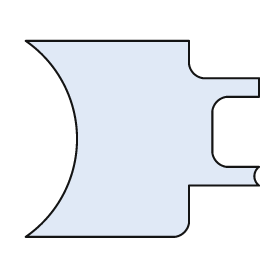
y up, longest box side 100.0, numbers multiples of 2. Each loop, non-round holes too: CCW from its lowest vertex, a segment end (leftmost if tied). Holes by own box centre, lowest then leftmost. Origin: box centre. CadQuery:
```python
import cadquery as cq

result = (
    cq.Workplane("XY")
    .moveTo(-50.0, -42.0)
    .lineTo(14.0, -42.0)
    .threePointArc((18.0, -40.0), (20.0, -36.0))
    .lineTo(20.0, -20.0)
    .lineTo(50.0, -20.0)
    .threePointArc((48.0, -16.0), (50.0, -12.0))
    .lineTo(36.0, -12.0)
    .threePointArc((32.0, -10.0), (30.0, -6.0))
    .lineTo(30.0, 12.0)
    .threePointArc((32.0, 16.0), (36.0, 18.0))
    .lineTo(50.0, 18.0)
    .lineTo(50.0, 26.0)
    .lineTo(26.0, 26.0)
    .threePointArc((22.0, 28.0), (20.0, 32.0))
    .lineTo(20.0, 42.0)
    .lineTo(-50.0, 42.0)
    .threePointArc((-28.0, 0.0), (-50.0, -42.0))
    .close()
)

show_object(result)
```